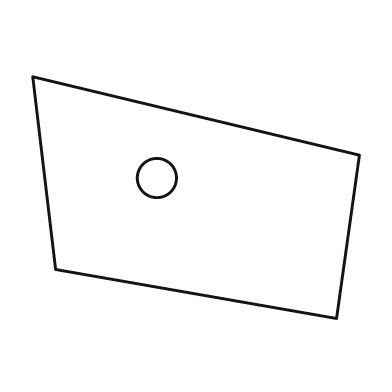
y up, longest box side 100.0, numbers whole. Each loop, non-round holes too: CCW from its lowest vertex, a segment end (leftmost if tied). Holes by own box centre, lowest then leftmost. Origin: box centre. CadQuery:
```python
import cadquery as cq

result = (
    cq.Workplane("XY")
    .moveTo(43.0, -37.0)
    .lineTo(50.0, 13.0)
    .lineTo(-50.0, 37.0)
    .lineTo(-43.0, -22.0)
    .close()
    .moveTo(-12.0, 6.0)
    .circle(6.0)
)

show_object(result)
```